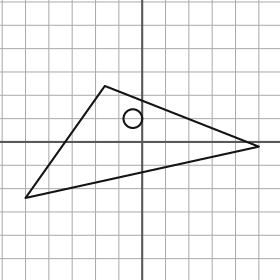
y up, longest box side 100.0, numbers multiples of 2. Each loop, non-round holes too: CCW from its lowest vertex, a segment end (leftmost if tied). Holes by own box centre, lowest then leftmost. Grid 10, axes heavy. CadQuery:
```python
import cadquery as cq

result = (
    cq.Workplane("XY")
    .moveTo(-50.0, -24.0)
    .lineTo(50.0, -2.0)
    .lineTo(-16.0, 24.0)
    .close()
    .moveTo(-4.0, 10.0)
    .circle(4.0)
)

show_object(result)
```